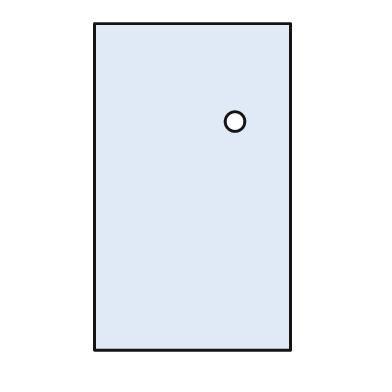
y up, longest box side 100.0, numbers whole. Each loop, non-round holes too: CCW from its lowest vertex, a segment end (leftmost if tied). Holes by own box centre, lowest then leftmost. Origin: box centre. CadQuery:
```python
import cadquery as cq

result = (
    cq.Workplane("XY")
    .moveTo(-30.0, -50.0)
    .lineTo(30.0, -50.0)
    .lineTo(30.0, 50.0)
    .lineTo(-30.0, 50.0)
    .close()
    .moveTo(13.0, 20.0)
    .circle(3.0)
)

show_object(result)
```